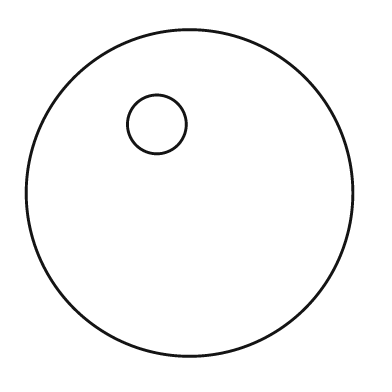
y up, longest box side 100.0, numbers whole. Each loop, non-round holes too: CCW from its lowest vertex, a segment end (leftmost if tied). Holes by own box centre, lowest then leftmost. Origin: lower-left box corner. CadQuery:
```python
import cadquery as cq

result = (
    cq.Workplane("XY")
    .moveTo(50.0, 50.0)
    .circle(50.0)
    .moveTo(40.0, 71.0)
    .circle(9.0)
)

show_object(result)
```